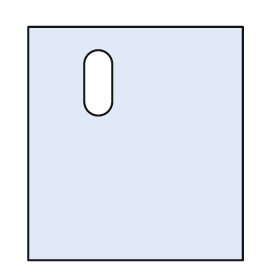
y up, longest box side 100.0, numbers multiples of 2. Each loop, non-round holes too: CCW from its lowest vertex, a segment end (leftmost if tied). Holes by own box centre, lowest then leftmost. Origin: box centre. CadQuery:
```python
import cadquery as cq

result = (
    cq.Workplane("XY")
    .moveTo(-46.0, -50.0)
    .lineTo(46.0, -50.0)
    .lineTo(46.0, 50.0)
    .lineTo(-46.0, 50.0)
    .close()
    .moveTo(-22.0, 18.0)
    .threePointArc((-16.0, 12.0), (-10.0, 18.0))
    .lineTo(-10.0, 34.0)
    .threePointArc((-16.0, 40.0), (-22.0, 34.0))
    .close()
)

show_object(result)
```